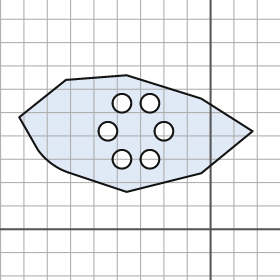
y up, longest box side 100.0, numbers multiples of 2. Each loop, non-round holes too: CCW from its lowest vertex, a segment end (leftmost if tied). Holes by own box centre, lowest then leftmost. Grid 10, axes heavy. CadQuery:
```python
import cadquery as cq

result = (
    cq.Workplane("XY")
    .moveTo(-36.0, 16.0)
    .lineTo(-4.0, 24.0)
    .lineTo(18.0, 42.0)
    .lineTo(-4.0, 56.0)
    .lineTo(-36.0, 66.0)
    .lineTo(-62.0, 64.0)
    .lineTo(-82.0, 48.0)
    .lineTo(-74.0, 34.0)
    .threePointArc((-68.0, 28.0), (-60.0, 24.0))
    .close()
    .moveTo(-38.0, 30.0)
    .circle(4.0)
    .moveTo(-26.0, 30.0)
    .circle(4.0)
    .moveTo(-44.0, 42.0)
    .circle(4.0)
    .moveTo(-20.0, 42.0)
    .circle(4.0)
    .moveTo(-38.0, 54.0)
    .circle(4.0)
    .moveTo(-26.0, 54.0)
    .circle(4.0)
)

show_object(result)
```